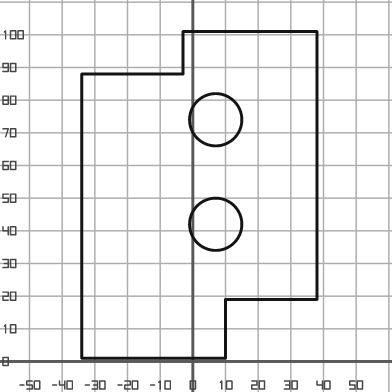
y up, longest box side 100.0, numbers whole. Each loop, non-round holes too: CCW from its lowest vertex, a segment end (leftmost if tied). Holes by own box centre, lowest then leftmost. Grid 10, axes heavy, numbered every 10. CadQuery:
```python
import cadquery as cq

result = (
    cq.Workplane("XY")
    .moveTo(-34.0, 1.0)
    .lineTo(10.0, 1.0)
    .lineTo(10.0, 19.0)
    .lineTo(38.0, 19.0)
    .lineTo(38.0, 101.0)
    .lineTo(-3.0, 101.0)
    .lineTo(-3.0, 88.0)
    .lineTo(-34.0, 88.0)
    .close()
    .moveTo(7.0, 42.0)
    .circle(8.0)
    .moveTo(7.0, 74.0)
    .circle(8.0)
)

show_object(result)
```